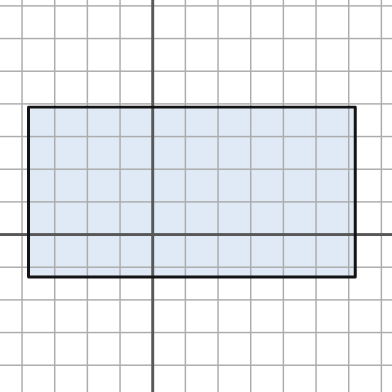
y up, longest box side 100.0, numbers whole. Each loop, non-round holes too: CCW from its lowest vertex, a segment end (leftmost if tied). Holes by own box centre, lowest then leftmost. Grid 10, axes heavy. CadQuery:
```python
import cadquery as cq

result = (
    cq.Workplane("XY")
    .moveTo(-38.0, -13.0)
    .lineTo(62.0, -13.0)
    .lineTo(62.0, 39.0)
    .lineTo(-38.0, 39.0)
    .close()
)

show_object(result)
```